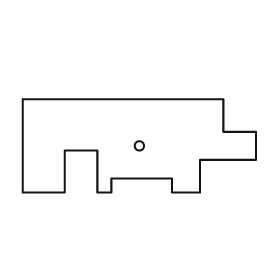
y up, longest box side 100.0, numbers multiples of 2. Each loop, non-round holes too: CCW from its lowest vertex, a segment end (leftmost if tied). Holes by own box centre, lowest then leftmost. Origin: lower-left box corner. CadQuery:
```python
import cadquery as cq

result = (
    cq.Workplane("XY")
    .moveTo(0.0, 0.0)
    .lineTo(18.0, 0.0)
    .lineTo(18.0, 18.0)
    .lineTo(32.0, 18.0)
    .lineTo(32.0, 0.0)
    .lineTo(38.0, 0.0)
    .lineTo(38.0, 6.0)
    .lineTo(64.0, 6.0)
    .lineTo(64.0, 0.0)
    .lineTo(76.0, 0.0)
    .lineTo(76.0, 14.0)
    .lineTo(100.0, 14.0)
    .lineTo(100.0, 26.0)
    .lineTo(86.0, 26.0)
    .lineTo(86.0, 40.0)
    .lineTo(0.0, 40.0)
    .close()
    .moveTo(50.0, 20.0)
    .circle(2.0)
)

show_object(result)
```